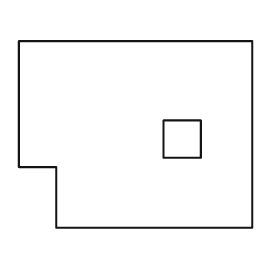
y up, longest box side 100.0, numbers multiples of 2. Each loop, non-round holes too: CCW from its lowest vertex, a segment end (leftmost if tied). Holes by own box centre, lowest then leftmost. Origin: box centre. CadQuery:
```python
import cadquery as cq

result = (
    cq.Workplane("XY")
    .moveTo(-34.0, -40.0)
    .lineTo(50.0, -40.0)
    .lineTo(50.0, 40.0)
    .lineTo(-50.0, 40.0)
    .lineTo(-50.0, -14.0)
    .lineTo(-34.0, -14.0)
    .close()
    .moveTo(12.0, -10.0)
    .lineTo(28.0, -10.0)
    .lineTo(28.0, 6.0)
    .lineTo(12.0, 6.0)
    .close()
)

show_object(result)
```